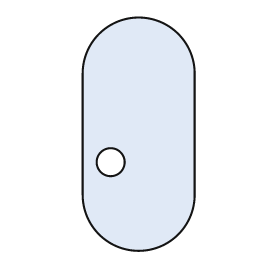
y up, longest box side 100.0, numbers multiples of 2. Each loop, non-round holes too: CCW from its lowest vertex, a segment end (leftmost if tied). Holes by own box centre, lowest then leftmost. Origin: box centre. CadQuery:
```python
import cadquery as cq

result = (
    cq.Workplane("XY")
    .moveTo(-24.0, -26.0)
    .threePointArc((0.0, -50.0), (24.0, -26.0))
    .lineTo(24.0, 26.0)
    .threePointArc((0.0, 50.0), (-24.0, 26.0))
    .close()
    .moveTo(-12.0, -12.0)
    .circle(6.0)
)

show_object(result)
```